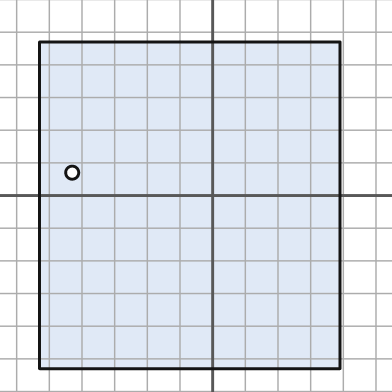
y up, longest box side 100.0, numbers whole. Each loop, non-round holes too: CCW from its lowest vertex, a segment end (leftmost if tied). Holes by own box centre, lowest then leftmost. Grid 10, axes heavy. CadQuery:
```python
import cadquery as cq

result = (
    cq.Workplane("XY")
    .moveTo(-53.0, -53.0)
    .lineTo(39.0, -53.0)
    .lineTo(39.0, 47.0)
    .lineTo(-53.0, 47.0)
    .close()
    .moveTo(-43.0, 7.0)
    .circle(2.0)
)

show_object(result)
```